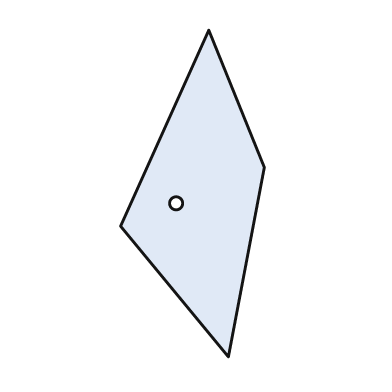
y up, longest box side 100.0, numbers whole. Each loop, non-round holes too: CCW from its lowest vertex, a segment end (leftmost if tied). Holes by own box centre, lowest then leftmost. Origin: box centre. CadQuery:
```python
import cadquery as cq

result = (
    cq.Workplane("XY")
    .moveTo(11.0, -50.0)
    .lineTo(22.0, 8.0)
    .lineTo(5.0, 50.0)
    .lineTo(-22.0, -10.0)
    .close()
    .moveTo(-5.0, -3.0)
    .circle(2.0)
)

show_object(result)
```